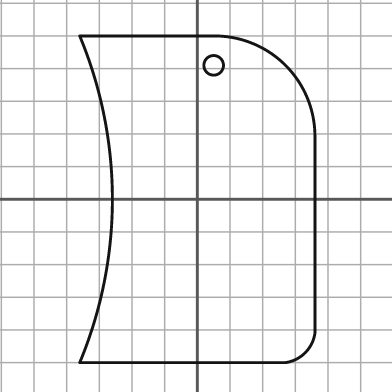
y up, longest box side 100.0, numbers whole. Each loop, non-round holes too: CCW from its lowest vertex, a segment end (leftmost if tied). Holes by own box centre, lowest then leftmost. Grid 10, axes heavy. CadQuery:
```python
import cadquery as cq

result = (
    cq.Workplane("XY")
    .moveTo(-36.0, -50.0)
    .lineTo(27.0, -50.0)
    .threePointArc((33.0, -47.0), (36.0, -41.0))
    .lineTo(36.0, 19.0)
    .threePointArc((27.0, 41.0), (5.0, 50.0))
    .lineTo(-36.0, 50.0)
    .threePointArc((-26.0, 0.0), (-36.0, -50.0))
    .close()
    .moveTo(5.0, 41.0)
    .circle(3.0)
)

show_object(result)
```